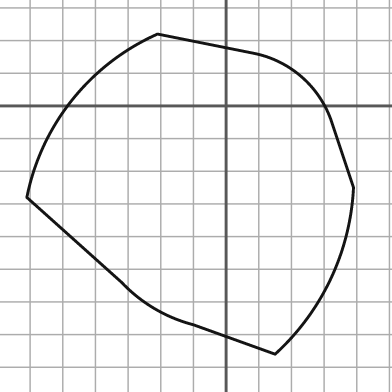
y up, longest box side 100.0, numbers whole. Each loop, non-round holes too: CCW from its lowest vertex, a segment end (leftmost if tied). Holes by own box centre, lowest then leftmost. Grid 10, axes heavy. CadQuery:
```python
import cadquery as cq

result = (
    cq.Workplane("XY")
    .moveTo(15.0, -76.0)
    .threePointArc((32.0, -53.0), (39.0, -25.0))
    .lineTo(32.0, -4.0)
    .threePointArc((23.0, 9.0), (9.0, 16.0))
    .lineTo(-21.0, 22.0)
    .threePointArc((-47.0, 2.0), (-61.0, -28.0))
    .lineTo(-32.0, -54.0)
    .threePointArc((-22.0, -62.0), (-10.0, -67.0))
    .close()
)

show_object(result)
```